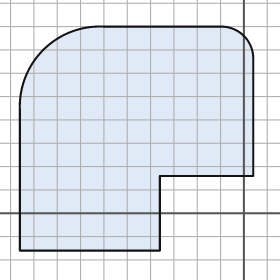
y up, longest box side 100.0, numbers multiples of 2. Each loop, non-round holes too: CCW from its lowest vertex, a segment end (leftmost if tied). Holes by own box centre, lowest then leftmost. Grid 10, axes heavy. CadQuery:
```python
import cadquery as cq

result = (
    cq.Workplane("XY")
    .moveTo(-96.0, -16.0)
    .lineTo(-36.0, -16.0)
    .lineTo(-36.0, 16.0)
    .lineTo(4.0, 16.0)
    .lineTo(4.0, 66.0)
    .threePointArc((0.0, 76.0), (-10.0, 80.0))
    .lineTo(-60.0, 80.0)
    .threePointArc((-86.0, 70.0), (-96.0, 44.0))
    .close()
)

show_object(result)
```